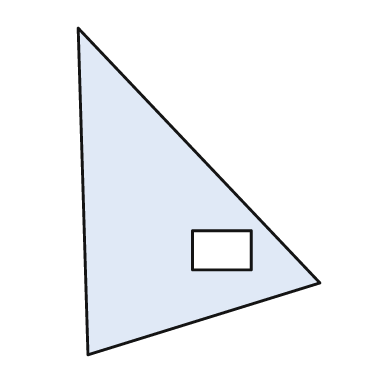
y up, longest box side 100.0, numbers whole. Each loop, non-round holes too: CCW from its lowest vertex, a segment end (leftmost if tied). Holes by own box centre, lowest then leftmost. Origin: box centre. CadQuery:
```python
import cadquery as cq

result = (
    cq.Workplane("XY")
    .moveTo(-34.0, -50.0)
    .lineTo(37.0, -28.0)
    .lineTo(-37.0, 50.0)
    .close()
    .moveTo(-2.0, -24.0)
    .lineTo(16.0, -24.0)
    .lineTo(16.0, -12.0)
    .lineTo(-2.0, -12.0)
    .close()
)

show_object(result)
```